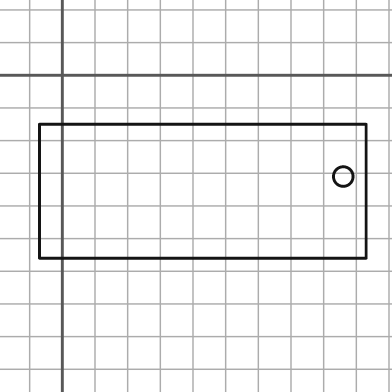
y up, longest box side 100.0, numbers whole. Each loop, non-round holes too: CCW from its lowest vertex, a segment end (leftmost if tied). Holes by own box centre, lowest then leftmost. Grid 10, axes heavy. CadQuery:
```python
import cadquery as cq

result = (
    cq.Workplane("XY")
    .moveTo(-7.0, -56.0)
    .lineTo(93.0, -56.0)
    .lineTo(93.0, -15.0)
    .lineTo(-7.0, -15.0)
    .close()
    .moveTo(86.0, -31.0)
    .circle(3.0)
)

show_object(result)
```